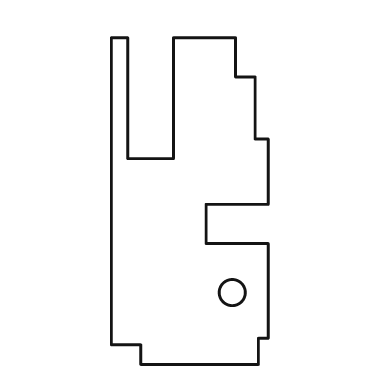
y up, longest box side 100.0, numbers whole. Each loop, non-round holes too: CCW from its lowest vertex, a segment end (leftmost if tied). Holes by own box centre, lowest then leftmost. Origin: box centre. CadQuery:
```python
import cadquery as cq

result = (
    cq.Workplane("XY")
    .moveTo(-15.0, -50.0)
    .lineTo(21.0, -50.0)
    .lineTo(21.0, -42.0)
    .lineTo(24.0, -42.0)
    .lineTo(24.0, -13.0)
    .lineTo(5.0, -13.0)
    .lineTo(5.0, -1.0)
    .lineTo(24.0, -1.0)
    .lineTo(24.0, 19.0)
    .lineTo(20.0, 19.0)
    .lineTo(20.0, 38.0)
    .lineTo(14.0, 38.0)
    .lineTo(14.0, 50.0)
    .lineTo(-5.0, 50.0)
    .lineTo(-5.0, 13.0)
    .lineTo(-19.0, 13.0)
    .lineTo(-19.0, 50.0)
    .lineTo(-24.0, 50.0)
    .lineTo(-24.0, -44.0)
    .lineTo(-15.0, -44.0)
    .close()
    .moveTo(13.0, -28.0)
    .circle(4.0)
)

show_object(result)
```